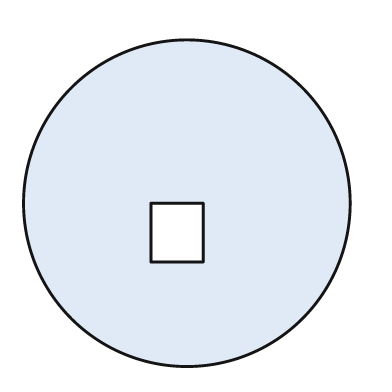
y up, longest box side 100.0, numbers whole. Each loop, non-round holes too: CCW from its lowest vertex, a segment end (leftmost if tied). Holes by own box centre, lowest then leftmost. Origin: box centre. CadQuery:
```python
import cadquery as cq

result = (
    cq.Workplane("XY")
    .moveTo(0.0, 0.0)
    .circle(50.0)
    .moveTo(-11.0, -18.0)
    .lineTo(5.0, -18.0)
    .lineTo(5.0, 0.0)
    .lineTo(-11.0, 0.0)
    .close()
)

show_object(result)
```